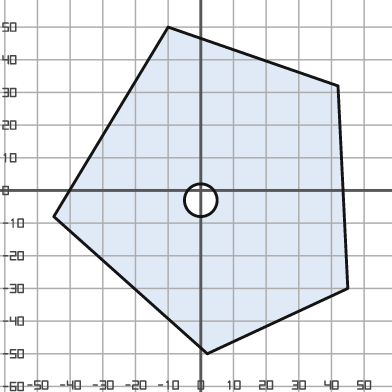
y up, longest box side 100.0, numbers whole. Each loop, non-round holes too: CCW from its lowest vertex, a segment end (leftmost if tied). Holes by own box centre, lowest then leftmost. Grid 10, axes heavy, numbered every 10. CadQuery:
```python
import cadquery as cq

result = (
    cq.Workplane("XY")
    .moveTo(2.0, -50.0)
    .lineTo(45.0, -30.0)
    .lineTo(42.0, 32.0)
    .lineTo(-10.0, 50.0)
    .lineTo(-45.0, -8.0)
    .close()
    .moveTo(0.0, -3.0)
    .circle(5.0)
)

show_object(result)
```